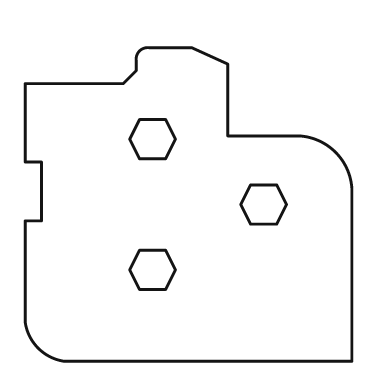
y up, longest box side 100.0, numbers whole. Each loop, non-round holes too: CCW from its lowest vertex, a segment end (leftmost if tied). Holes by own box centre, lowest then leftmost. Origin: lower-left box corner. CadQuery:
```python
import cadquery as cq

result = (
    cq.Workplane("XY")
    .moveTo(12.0, 0.0)
    .lineTo(100.0, 0.0)
    .lineTo(100.0, 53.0)
    .threePointArc((95.0, 64.0), (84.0, 69.0))
    .lineTo(62.0, 69.0)
    .lineTo(62.0, 91.0)
    .lineTo(51.0, 96.0)
    .lineTo(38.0, 96.0)
    .threePointArc((35.0, 95.0), (34.0, 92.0))
    .lineTo(34.0, 89.0)
    .lineTo(30.0, 85.0)
    .lineTo(0.0, 85.0)
    .lineTo(0.0, 61.0)
    .lineTo(5.0, 61.0)
    .lineTo(5.0, 43.0)
    .lineTo(0.0, 43.0)
    .lineTo(0.0, 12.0)
    .threePointArc((4.0, 4.0), (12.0, 0.0))
    .close()
    .moveTo(35.0, 22.0)
    .lineTo(43.0, 22.0)
    .lineTo(46.0, 28.0)
    .lineTo(43.0, 34.0)
    .lineTo(35.0, 34.0)
    .lineTo(32.0, 28.0)
    .close()
    .moveTo(69.0, 42.0)
    .lineTo(77.0, 42.0)
    .lineTo(80.0, 48.0)
    .lineTo(77.0, 54.0)
    .lineTo(69.0, 54.0)
    .lineTo(66.0, 48.0)
    .close()
    .moveTo(35.0, 62.0)
    .lineTo(43.0, 62.0)
    .lineTo(46.0, 68.0)
    .lineTo(43.0, 74.0)
    .lineTo(35.0, 74.0)
    .lineTo(32.0, 68.0)
    .close()
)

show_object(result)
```